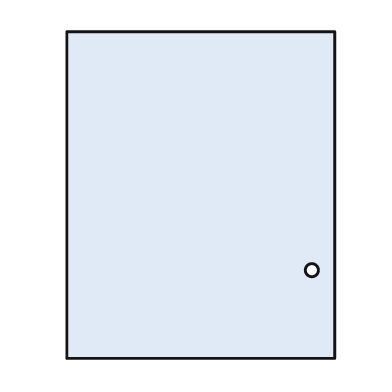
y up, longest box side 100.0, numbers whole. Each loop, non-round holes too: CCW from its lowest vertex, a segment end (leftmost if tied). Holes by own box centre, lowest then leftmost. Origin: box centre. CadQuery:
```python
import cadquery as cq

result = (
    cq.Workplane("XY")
    .moveTo(-41.0, -50.0)
    .lineTo(41.0, -50.0)
    .lineTo(41.0, 50.0)
    .lineTo(-41.0, 50.0)
    .close()
    .moveTo(34.0, -23.0)
    .circle(2.0)
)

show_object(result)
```